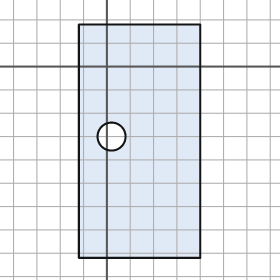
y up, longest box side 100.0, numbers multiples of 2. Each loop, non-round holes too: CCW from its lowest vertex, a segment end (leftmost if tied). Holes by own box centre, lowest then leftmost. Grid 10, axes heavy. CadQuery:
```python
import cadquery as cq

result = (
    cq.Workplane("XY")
    .moveTo(-12.0, -82.0)
    .lineTo(40.0, -82.0)
    .lineTo(40.0, 18.0)
    .lineTo(-12.0, 18.0)
    .close()
    .moveTo(2.0, -30.0)
    .circle(6.0)
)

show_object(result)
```